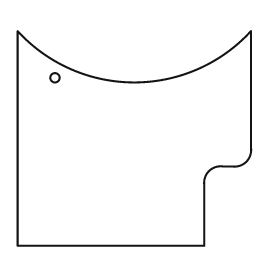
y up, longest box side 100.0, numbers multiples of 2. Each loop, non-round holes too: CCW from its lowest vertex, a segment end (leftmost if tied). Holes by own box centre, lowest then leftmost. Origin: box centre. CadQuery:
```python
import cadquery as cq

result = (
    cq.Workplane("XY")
    .moveTo(-50.0, -46.0)
    .lineTo(30.0, -46.0)
    .lineTo(30.0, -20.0)
    .threePointArc((32.0, -14.0), (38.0, -12.0))
    .lineTo(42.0, -12.0)
    .threePointArc((48.0, -10.0), (50.0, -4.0))
    .lineTo(50.0, 46.0)
    .threePointArc((0.0, 24.0), (-50.0, 46.0))
    .close()
    .moveTo(-34.0, 26.0)
    .circle(2.0)
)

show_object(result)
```